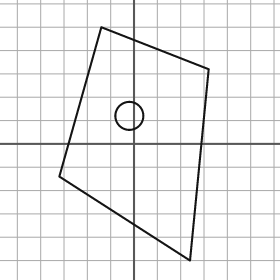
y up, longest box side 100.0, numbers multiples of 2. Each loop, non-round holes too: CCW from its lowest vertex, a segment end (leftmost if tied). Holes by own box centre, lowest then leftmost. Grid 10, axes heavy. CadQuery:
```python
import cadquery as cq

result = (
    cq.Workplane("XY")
    .moveTo(24.0, -50.0)
    .lineTo(32.0, 32.0)
    .lineTo(-14.0, 50.0)
    .lineTo(-32.0, -14.0)
    .close()
    .moveTo(-2.0, 12.0)
    .circle(6.0)
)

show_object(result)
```